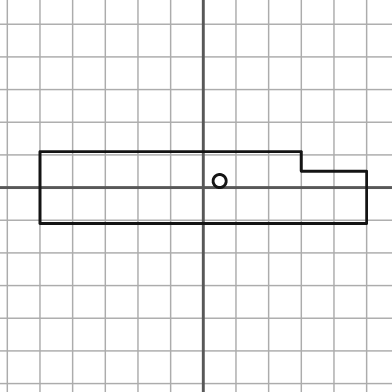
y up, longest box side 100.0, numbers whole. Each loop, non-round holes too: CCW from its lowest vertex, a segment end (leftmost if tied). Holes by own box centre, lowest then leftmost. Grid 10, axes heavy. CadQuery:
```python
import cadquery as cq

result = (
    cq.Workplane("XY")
    .moveTo(-50.0, -11.0)
    .lineTo(50.0, -11.0)
    .lineTo(50.0, 5.0)
    .lineTo(30.0, 5.0)
    .lineTo(30.0, 11.0)
    .lineTo(-50.0, 11.0)
    .close()
    .moveTo(5.0, 2.0)
    .circle(2.0)
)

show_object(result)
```